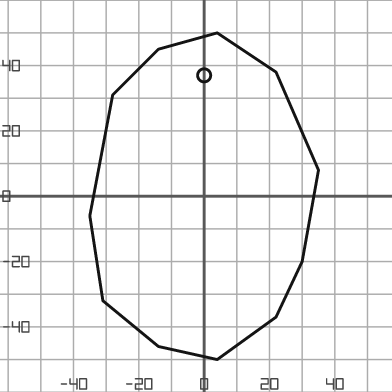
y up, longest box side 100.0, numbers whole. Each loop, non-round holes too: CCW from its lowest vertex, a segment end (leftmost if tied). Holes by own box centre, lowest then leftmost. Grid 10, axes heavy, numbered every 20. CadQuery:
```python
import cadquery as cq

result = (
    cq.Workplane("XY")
    .moveTo(4.0, -50.0)
    .lineTo(22.0, -37.0)
    .lineTo(30.0, -20.0)
    .lineTo(35.0, 8.0)
    .lineTo(22.0, 38.0)
    .lineTo(4.0, 50.0)
    .lineTo(-14.0, 45.0)
    .lineTo(-28.0, 31.0)
    .lineTo(-35.0, -6.0)
    .lineTo(-31.0, -32.0)
    .lineTo(-14.0, -46.0)
    .close()
    .moveTo(0.0, 37.0)
    .circle(2.0)
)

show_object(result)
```